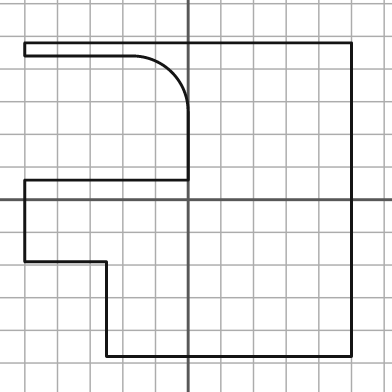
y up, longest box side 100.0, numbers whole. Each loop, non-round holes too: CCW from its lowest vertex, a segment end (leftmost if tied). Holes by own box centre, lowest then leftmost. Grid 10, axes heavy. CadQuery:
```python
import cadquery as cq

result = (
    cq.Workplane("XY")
    .moveTo(-25.0, -48.0)
    .lineTo(50.0, -48.0)
    .lineTo(50.0, 48.0)
    .lineTo(-50.0, 48.0)
    .lineTo(-50.0, 44.0)
    .lineTo(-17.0, 44.0)
    .threePointArc((-5.0, 39.0), (0.0, 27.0))
    .lineTo(0.0, 6.0)
    .lineTo(-50.0, 6.0)
    .lineTo(-50.0, -19.0)
    .lineTo(-25.0, -19.0)
    .close()
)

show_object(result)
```